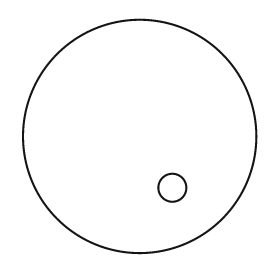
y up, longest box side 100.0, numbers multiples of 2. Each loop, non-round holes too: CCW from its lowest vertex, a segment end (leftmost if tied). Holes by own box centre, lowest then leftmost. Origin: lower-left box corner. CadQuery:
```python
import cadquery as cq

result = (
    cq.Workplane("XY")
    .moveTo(50.0, 50.0)
    .circle(50.0)
    .moveTo(64.0, 28.0)
    .circle(6.0)
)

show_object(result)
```